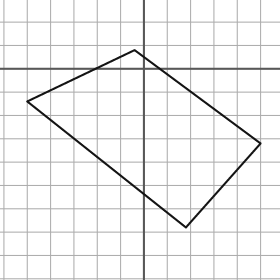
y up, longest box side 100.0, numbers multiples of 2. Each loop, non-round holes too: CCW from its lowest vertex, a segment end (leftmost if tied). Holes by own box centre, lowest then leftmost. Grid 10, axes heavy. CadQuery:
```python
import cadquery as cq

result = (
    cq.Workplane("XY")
    .moveTo(18.0, -68.0)
    .lineTo(50.0, -32.0)
    .lineTo(-4.0, 8.0)
    .lineTo(-50.0, -14.0)
    .close()
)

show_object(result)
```